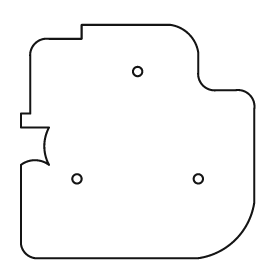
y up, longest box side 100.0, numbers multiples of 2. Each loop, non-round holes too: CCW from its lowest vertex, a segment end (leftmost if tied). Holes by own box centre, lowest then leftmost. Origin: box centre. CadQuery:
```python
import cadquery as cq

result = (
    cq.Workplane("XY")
    .moveTo(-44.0, -50.0)
    .lineTo(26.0, -50.0)
    .threePointArc((42.0, -42.0), (50.0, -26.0))
    .lineTo(50.0, 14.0)
    .threePointArc((48.0, 20.0), (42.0, 22.0))
    .lineTo(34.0, 22.0)
    .threePointArc((28.0, 24.0), (26.0, 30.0))
    .lineTo(26.0, 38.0)
    .threePointArc((22.0, 46.0), (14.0, 50.0))
    .lineTo(-24.0, 50.0)
    .lineTo(-24.0, 44.0)
    .lineTo(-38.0, 44.0)
    .threePointArc((-44.0, 42.0), (-46.0, 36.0))
    .lineTo(-46.0, 12.0)
    .lineTo(-50.0, 12.0)
    .lineTo(-50.0, 6.0)
    .lineTo(-38.0, 6.0)
    .threePointArc((-40.0, -2.0), (-38.0, -10.0))
    .threePointArc((-44.0, -8.0), (-50.0, -10.0))
    .lineTo(-50.0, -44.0)
    .threePointArc((-48.0, -48.0), (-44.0, -50.0))
    .close()
    .moveTo(-26.0, -16.0)
    .circle(2.0)
    .moveTo(26.0, -16.0)
    .circle(2.0)
    .moveTo(0.0, 30.0)
    .circle(2.0)
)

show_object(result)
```